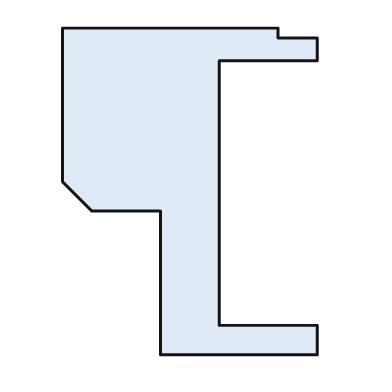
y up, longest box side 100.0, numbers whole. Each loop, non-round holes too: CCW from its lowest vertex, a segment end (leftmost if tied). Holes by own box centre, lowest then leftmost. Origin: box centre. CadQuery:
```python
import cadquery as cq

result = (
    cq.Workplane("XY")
    .moveTo(-9.0, -50.0)
    .lineTo(39.0, -50.0)
    .lineTo(39.0, -41.0)
    .lineTo(9.0, -41.0)
    .lineTo(9.0, 40.0)
    .lineTo(39.0, 40.0)
    .lineTo(39.0, 47.0)
    .lineTo(27.0, 47.0)
    .lineTo(27.0, 50.0)
    .lineTo(-39.0, 50.0)
    .lineTo(-39.0, 3.0)
    .lineTo(-30.0, -6.0)
    .lineTo(-9.0, -6.0)
    .close()
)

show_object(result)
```